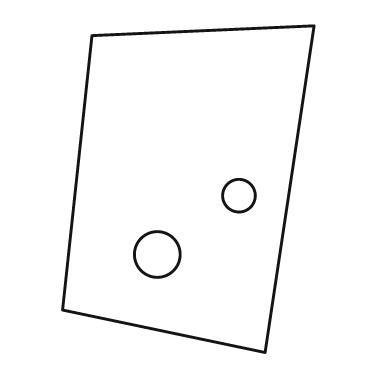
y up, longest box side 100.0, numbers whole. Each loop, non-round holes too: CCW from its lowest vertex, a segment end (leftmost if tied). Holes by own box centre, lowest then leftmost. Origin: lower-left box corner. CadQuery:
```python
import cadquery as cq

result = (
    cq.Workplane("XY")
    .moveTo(62.0, 0.0)
    .lineTo(77.0, 100.0)
    .lineTo(9.0, 97.0)
    .lineTo(0.0, 13.0)
    .close()
    .moveTo(29.0, 30.0)
    .circle(7.0)
    .moveTo(54.0, 48.0)
    .circle(5.0)
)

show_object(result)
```